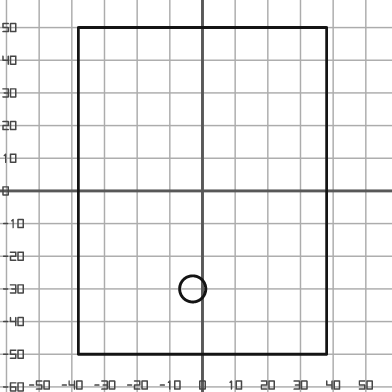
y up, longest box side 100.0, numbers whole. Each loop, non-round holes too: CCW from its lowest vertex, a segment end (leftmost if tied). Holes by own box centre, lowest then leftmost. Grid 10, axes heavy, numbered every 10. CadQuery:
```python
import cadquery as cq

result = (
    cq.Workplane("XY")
    .moveTo(-38.0, -50.0)
    .lineTo(38.0, -50.0)
    .lineTo(38.0, 50.0)
    .lineTo(-38.0, 50.0)
    .close()
    .moveTo(-3.0, -30.0)
    .circle(4.0)
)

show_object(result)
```